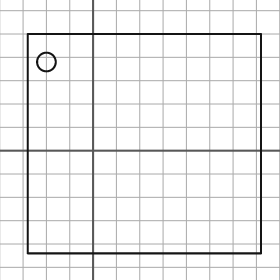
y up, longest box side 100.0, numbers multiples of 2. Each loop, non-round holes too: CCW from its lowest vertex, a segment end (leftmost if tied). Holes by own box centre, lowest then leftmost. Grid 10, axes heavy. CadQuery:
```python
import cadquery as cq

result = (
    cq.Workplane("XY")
    .moveTo(-28.0, -44.0)
    .lineTo(72.0, -44.0)
    .lineTo(72.0, 50.0)
    .lineTo(-28.0, 50.0)
    .close()
    .moveTo(-20.0, 38.0)
    .circle(4.0)
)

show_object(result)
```